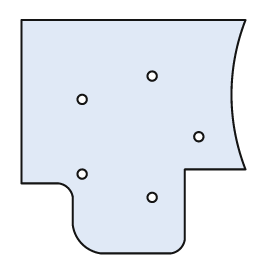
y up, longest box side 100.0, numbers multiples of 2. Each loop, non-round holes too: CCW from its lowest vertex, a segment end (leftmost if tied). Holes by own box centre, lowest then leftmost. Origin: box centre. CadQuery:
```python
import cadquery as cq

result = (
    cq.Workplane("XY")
    .moveTo(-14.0, -50.0)
    .lineTo(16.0, -50.0)
    .threePointArc((20.0, -48.0), (22.0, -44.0))
    .lineTo(22.0, -14.0)
    .lineTo(48.0, -14.0)
    .threePointArc((42.0, 18.0), (48.0, 50.0))
    .lineTo(-48.0, 50.0)
    .lineTo(-48.0, -20.0)
    .lineTo(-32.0, -20.0)
    .threePointArc((-28.0, -22.0), (-26.0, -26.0))
    .lineTo(-26.0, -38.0)
    .threePointArc((-22.0, -46.0), (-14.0, -50.0))
    .close()
    .moveTo(8.0, -26.0)
    .circle(2.0)
    .moveTo(-22.0, -16.0)
    .circle(2.0)
    .moveTo(28.0, 0.0)
    .circle(2.0)
    .moveTo(-22.0, 16.0)
    .circle(2.0)
    .moveTo(8.0, 26.0)
    .circle(2.0)
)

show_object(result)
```